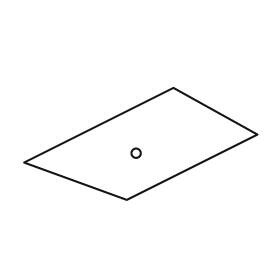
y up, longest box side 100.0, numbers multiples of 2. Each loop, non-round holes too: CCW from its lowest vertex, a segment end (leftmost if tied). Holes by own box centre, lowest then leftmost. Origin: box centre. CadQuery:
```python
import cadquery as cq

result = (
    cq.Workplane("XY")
    .moveTo(-6.0, -24.0)
    .lineTo(50.0, 4.0)
    .lineTo(14.0, 24.0)
    .lineTo(-50.0, -8.0)
    .close()
    .moveTo(-2.0, -4.0)
    .circle(2.0)
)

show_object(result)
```